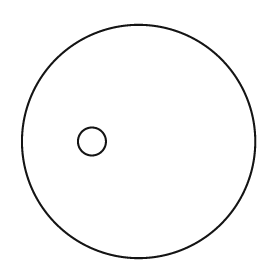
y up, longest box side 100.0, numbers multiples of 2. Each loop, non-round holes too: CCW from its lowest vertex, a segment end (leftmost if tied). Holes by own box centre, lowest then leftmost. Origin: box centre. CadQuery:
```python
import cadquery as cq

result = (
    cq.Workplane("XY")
    .moveTo(0.0, 0.0)
    .circle(50.0)
    .moveTo(-20.0, 0.0)
    .circle(6.0)
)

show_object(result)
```